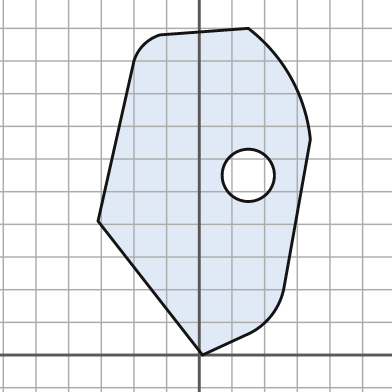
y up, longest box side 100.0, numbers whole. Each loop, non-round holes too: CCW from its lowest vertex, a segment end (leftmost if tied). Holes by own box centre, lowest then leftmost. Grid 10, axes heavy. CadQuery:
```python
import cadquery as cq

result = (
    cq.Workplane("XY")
    .moveTo(1.0, 0.0)
    .lineTo(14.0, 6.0)
    .threePointArc((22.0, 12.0), (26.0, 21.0))
    .lineTo(34.0, 66.0)
    .threePointArc((28.0, 85.0), (15.0, 100.0))
    .lineTo(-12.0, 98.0)
    .threePointArc((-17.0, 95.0), (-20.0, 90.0))
    .lineTo(-31.0, 41.0)
    .close()
    .moveTo(15.0, 55.0)
    .circle(8.0)
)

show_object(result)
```